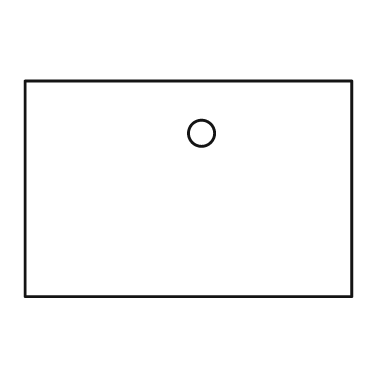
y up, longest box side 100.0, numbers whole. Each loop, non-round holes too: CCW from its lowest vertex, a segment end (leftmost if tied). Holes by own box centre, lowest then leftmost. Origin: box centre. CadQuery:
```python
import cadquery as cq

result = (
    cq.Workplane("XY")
    .moveTo(-50.0, -33.0)
    .lineTo(50.0, -33.0)
    .lineTo(50.0, 33.0)
    .lineTo(-50.0, 33.0)
    .close()
    .moveTo(4.0, 17.0)
    .circle(4.0)
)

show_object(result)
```